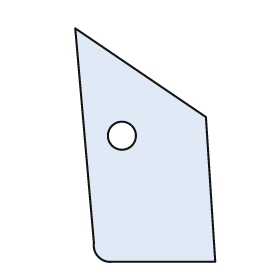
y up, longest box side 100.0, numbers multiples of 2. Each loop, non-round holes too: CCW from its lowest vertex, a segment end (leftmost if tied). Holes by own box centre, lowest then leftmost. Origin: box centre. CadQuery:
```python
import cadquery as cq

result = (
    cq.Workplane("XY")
    .moveTo(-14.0, -50.0)
    .lineTo(30.0, -50.0)
    .lineTo(26.0, 12.0)
    .lineTo(-30.0, 50.0)
    .lineTo(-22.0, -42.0)
    .threePointArc((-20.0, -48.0), (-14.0, -50.0))
    .close()
    .moveTo(-10.0, 4.0)
    .circle(6.0)
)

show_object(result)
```